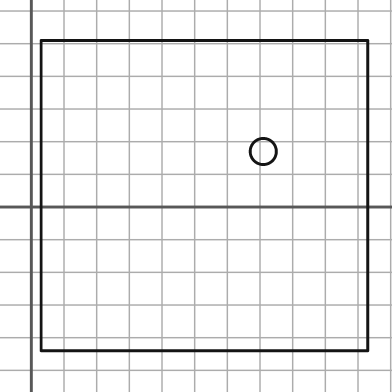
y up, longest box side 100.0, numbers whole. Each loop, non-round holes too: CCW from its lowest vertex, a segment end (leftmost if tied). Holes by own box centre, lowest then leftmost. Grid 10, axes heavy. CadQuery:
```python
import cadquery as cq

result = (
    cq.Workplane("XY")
    .moveTo(3.0, -44.0)
    .lineTo(103.0, -44.0)
    .lineTo(103.0, 51.0)
    .lineTo(3.0, 51.0)
    .close()
    .moveTo(71.0, 17.0)
    .circle(4.0)
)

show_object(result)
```